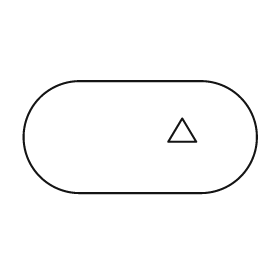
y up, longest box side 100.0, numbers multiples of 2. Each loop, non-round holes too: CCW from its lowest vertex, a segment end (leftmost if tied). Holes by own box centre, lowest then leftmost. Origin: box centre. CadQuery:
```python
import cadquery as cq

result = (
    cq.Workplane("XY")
    .moveTo(-26.0, -24.0)
    .lineTo(26.0, -24.0)
    .threePointArc((50.0, 0.0), (26.0, 24.0))
    .lineTo(-26.0, 24.0)
    .threePointArc((-50.0, 0.0), (-26.0, -24.0))
    .close()
    .moveTo(12.0, -2.0)
    .lineTo(24.0, -2.0)
    .lineTo(18.0, 8.0)
    .close()
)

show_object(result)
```